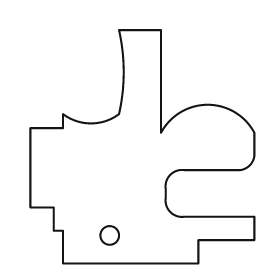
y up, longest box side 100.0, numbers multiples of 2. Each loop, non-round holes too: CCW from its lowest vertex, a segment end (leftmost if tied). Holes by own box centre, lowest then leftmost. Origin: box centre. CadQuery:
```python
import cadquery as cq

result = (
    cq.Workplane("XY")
    .moveTo(-34.0, -50.0)
    .lineTo(24.0, -50.0)
    .lineTo(24.0, -40.0)
    .lineTo(48.0, -40.0)
    .lineTo(48.0, -30.0)
    .lineTo(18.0, -30.0)
    .threePointArc((12.0, -28.0), (10.0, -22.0))
    .lineTo(10.0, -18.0)
    .threePointArc((12.0, -12.0), (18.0, -10.0))
    .lineTo(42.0, -10.0)
    .threePointArc((46.0, -8.0), (48.0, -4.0))
    .lineTo(48.0, 6.0)
    .threePointArc((28.0, 18.0), (8.0, 6.0))
    .lineTo(8.0, 50.0)
    .lineTo(-10.0, 50.0)
    .threePointArc((-8.0, 32.0), (-10.0, 14.0))
    .threePointArc((-22.0, 10.0), (-34.0, 14.0))
    .lineTo(-34.0, 8.0)
    .lineTo(-48.0, 8.0)
    .lineTo(-48.0, -26.0)
    .lineTo(-38.0, -26.0)
    .lineTo(-38.0, -36.0)
    .lineTo(-34.0, -36.0)
    .close()
    .moveTo(-14.0, -38.0)
    .circle(4.0)
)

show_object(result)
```